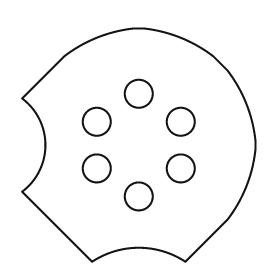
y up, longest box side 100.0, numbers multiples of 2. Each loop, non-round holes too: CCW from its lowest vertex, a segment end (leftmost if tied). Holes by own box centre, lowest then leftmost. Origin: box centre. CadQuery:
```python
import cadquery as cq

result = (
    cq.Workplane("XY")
    .moveTo(-20.0, -50.0)
    .threePointArc((0.0, -44.0), (20.0, -50.0))
    .lineTo(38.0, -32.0)
    .threePointArc((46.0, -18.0), (50.0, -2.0))
    .lineTo(50.0, 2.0)
    .threePointArc((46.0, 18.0), (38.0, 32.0))
    .lineTo(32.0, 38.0)
    .threePointArc((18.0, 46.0), (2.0, 50.0))
    .lineTo(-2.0, 50.0)
    .threePointArc((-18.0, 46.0), (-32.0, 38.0))
    .lineTo(-50.0, 20.0)
    .threePointArc((-40.0, 0.0), (-50.0, -20.0))
    .close()
    .moveTo(0.0, -22.0)
    .circle(6.0)
    .moveTo(-18.0, -10.0)
    .circle(6.0)
    .moveTo(18.0, -10.0)
    .circle(6.0)
    .moveTo(-18.0, 10.0)
    .circle(6.0)
    .moveTo(18.0, 10.0)
    .circle(6.0)
    .moveTo(0.0, 22.0)
    .circle(6.0)
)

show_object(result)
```